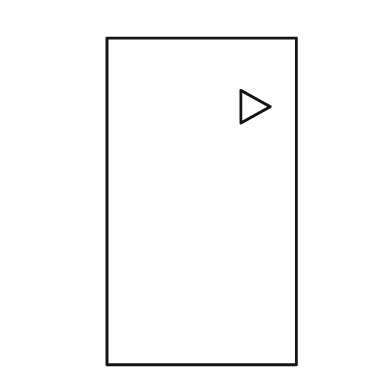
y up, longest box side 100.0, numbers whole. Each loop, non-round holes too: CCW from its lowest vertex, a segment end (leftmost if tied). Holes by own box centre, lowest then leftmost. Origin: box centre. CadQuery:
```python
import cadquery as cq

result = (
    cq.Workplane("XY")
    .moveTo(-29.0, -50.0)
    .lineTo(29.0, -50.0)
    .lineTo(29.0, 50.0)
    .lineTo(-29.0, 50.0)
    .close()
    .moveTo(12.0, 24.0)
    .lineTo(21.0, 29.0)
    .lineTo(12.0, 34.0)
    .close()
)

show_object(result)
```